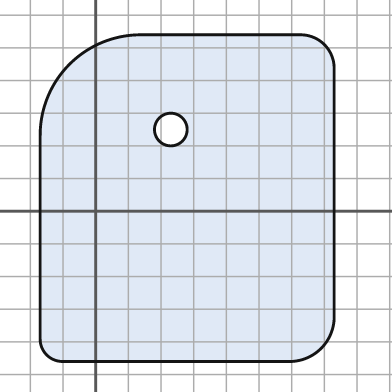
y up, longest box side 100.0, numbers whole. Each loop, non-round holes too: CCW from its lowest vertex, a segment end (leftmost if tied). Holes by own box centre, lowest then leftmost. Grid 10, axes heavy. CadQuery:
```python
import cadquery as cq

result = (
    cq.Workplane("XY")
    .moveTo(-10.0, -46.0)
    .lineTo(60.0, -46.0)
    .threePointArc((69.0, -42.0), (73.0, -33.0))
    .lineTo(73.0, 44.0)
    .threePointArc((70.0, 51.0), (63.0, 54.0))
    .lineTo(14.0, 54.0)
    .threePointArc((-8.0, 45.0), (-17.0, 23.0))
    .lineTo(-17.0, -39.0)
    .threePointArc((-15.0, -44.0), (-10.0, -46.0))
    .close()
    .moveTo(23.0, 25.0)
    .circle(5.0)
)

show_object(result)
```